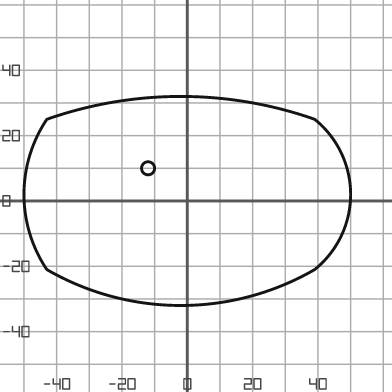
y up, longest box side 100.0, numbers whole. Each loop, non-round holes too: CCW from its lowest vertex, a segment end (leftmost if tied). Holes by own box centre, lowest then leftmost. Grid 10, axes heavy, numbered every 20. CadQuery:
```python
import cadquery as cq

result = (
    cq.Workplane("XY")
    .moveTo(-43.0, -21.0)
    .threePointArc((-2.0, -32.0), (39.0, -21.0))
    .threePointArc((50.0, 2.0), (39.0, 25.0))
    .threePointArc((-2.0, 32.0), (-43.0, 25.0))
    .threePointArc((-50.0, 2.0), (-43.0, -21.0))
    .close()
    .moveTo(-12.0, 10.0)
    .circle(2.0)
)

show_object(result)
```